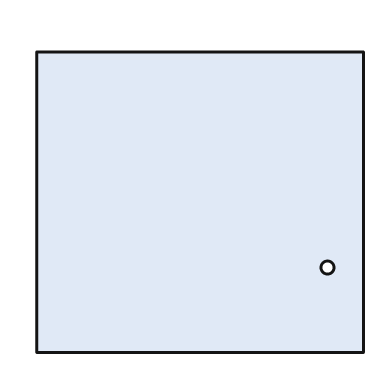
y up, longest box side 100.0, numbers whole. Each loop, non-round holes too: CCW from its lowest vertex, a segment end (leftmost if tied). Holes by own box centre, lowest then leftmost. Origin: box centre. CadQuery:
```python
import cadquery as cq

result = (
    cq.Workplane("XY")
    .moveTo(-50.0, -46.0)
    .lineTo(50.0, -46.0)
    .lineTo(50.0, 46.0)
    .lineTo(-50.0, 46.0)
    .close()
    .moveTo(39.0, -20.0)
    .circle(2.0)
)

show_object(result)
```